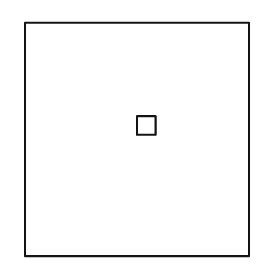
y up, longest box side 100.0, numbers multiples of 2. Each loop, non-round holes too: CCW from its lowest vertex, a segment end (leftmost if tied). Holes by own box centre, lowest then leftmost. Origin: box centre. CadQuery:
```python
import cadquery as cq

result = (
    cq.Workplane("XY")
    .moveTo(-48.0, -50.0)
    .lineTo(48.0, -50.0)
    .lineTo(48.0, 50.0)
    .lineTo(-48.0, 50.0)
    .close()
    .moveTo(0.0, 2.0)
    .lineTo(8.0, 2.0)
    .lineTo(8.0, 10.0)
    .lineTo(0.0, 10.0)
    .close()
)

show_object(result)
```